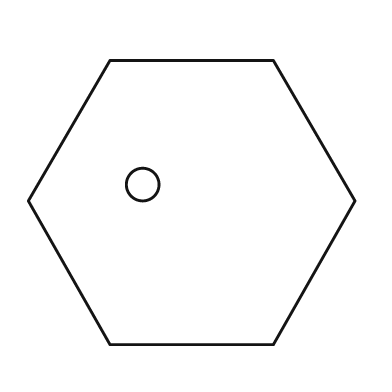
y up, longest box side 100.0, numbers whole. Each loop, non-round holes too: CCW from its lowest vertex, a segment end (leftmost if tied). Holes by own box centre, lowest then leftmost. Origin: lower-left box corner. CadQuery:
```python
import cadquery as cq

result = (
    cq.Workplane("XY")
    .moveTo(25.0, 0.0)
    .lineTo(75.0, 0.0)
    .lineTo(100.0, 44.0)
    .lineTo(75.0, 87.0)
    .lineTo(25.0, 87.0)
    .lineTo(0.0, 44.0)
    .close()
    .moveTo(35.0, 49.0)
    .circle(5.0)
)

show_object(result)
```